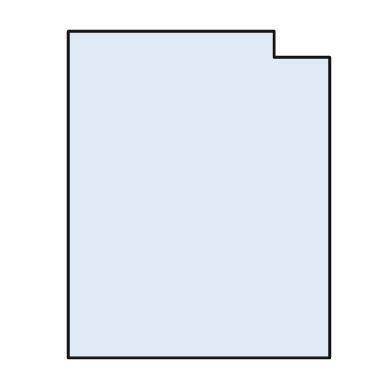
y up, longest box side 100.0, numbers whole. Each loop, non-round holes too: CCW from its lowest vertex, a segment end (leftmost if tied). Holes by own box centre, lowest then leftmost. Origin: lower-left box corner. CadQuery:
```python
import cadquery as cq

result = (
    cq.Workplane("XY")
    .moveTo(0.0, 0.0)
    .lineTo(80.0, 0.0)
    .lineTo(80.0, 92.0)
    .lineTo(63.0, 92.0)
    .lineTo(63.0, 100.0)
    .lineTo(0.0, 100.0)
    .close()
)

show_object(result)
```